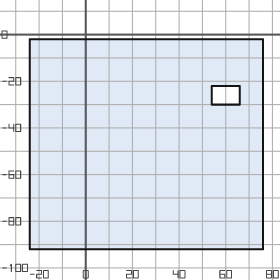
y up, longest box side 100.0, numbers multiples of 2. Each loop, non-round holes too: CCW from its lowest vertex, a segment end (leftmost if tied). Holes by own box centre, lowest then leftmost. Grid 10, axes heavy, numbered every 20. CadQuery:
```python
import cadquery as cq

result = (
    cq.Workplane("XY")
    .moveTo(-24.0, -92.0)
    .lineTo(76.0, -92.0)
    .lineTo(76.0, -2.0)
    .lineTo(-24.0, -2.0)
    .close()
    .moveTo(54.0, -30.0)
    .lineTo(66.0, -30.0)
    .lineTo(66.0, -22.0)
    .lineTo(54.0, -22.0)
    .close()
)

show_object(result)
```